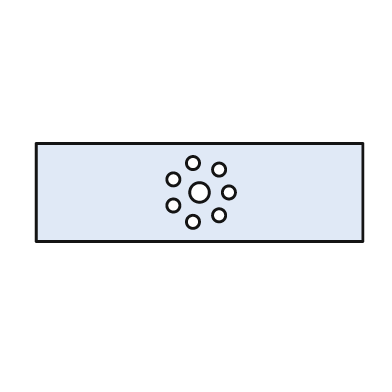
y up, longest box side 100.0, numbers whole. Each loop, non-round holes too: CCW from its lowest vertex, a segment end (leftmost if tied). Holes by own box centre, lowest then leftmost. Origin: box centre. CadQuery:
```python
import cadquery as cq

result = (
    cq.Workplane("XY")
    .moveTo(-50.0, -15.0)
    .lineTo(50.0, -15.0)
    .lineTo(50.0, 15.0)
    .lineTo(-50.0, 15.0)
    .close()
    .moveTo(-2.0, -9.0)
    .circle(2.0)
    .moveTo(6.0, -7.0)
    .circle(2.0)
    .moveTo(-8.0, -4.0)
    .circle(2.0)
    .moveTo(0.0, 0.0)
    .circle(3.0)
    .moveTo(9.0, 0.0)
    .circle(2.0)
    .moveTo(-8.0, 4.0)
    .circle(2.0)
    .moveTo(6.0, 7.0)
    .circle(2.0)
    .moveTo(-2.0, 9.0)
    .circle(2.0)
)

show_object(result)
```